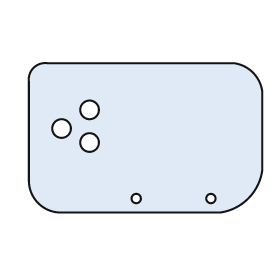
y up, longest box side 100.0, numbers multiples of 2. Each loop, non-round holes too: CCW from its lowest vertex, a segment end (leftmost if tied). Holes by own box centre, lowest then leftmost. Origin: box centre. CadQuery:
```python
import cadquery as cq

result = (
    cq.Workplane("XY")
    .moveTo(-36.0, -32.0)
    .lineTo(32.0, -32.0)
    .threePointArc((44.0, -26.0), (50.0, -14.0))
    .lineTo(50.0, 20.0)
    .threePointArc((46.0, 28.0), (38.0, 32.0))
    .lineTo(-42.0, 32.0)
    .threePointArc((-48.0, 30.0), (-50.0, 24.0))
    .lineTo(-50.0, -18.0)
    .threePointArc((-46.0, -28.0), (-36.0, -32.0))
    .close()
    .moveTo(-4.0, -26.0)
    .circle(2.0)
    .moveTo(28.0, -26.0)
    .circle(2.0)
    .moveTo(-24.0, -2.0)
    .circle(4.0)
    .moveTo(-36.0, 4.0)
    .circle(4.0)
    .moveTo(-24.0, 12.0)
    .circle(4.0)
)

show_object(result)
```